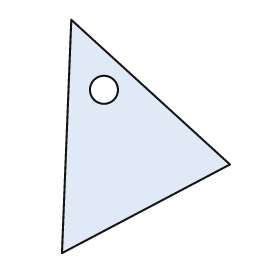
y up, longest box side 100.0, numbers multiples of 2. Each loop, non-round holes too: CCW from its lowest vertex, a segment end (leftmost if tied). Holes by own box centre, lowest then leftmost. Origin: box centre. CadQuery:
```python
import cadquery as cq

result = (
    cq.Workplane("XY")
    .moveTo(-36.0, -50.0)
    .lineTo(36.0, -12.0)
    .lineTo(-32.0, 50.0)
    .close()
    .moveTo(-18.0, 20.0)
    .circle(6.0)
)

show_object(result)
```